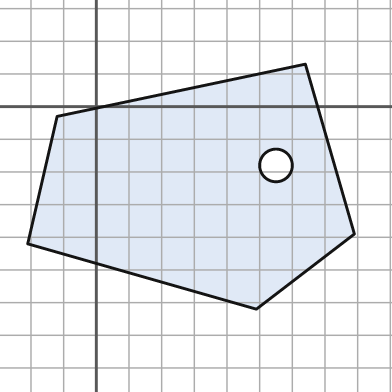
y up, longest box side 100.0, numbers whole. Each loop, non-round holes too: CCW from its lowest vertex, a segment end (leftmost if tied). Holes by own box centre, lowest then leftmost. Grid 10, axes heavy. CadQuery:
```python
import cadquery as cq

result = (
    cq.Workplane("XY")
    .moveTo(49.0, -62.0)
    .lineTo(79.0, -39.0)
    .lineTo(64.0, 13.0)
    .lineTo(-12.0, -3.0)
    .lineTo(-21.0, -42.0)
    .close()
    .moveTo(55.0, -18.0)
    .circle(5.0)
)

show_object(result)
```